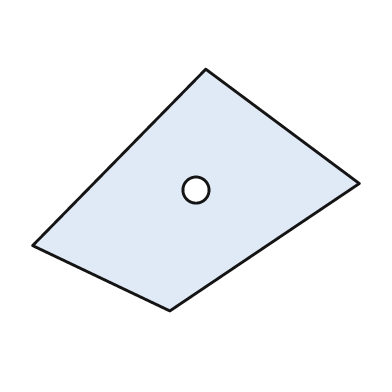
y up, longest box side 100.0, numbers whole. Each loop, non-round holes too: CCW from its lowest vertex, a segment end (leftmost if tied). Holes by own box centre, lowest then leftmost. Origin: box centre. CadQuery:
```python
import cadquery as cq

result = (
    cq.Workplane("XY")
    .moveTo(-8.0, -37.0)
    .lineTo(50.0, 2.0)
    .lineTo(3.0, 37.0)
    .lineTo(-50.0, -17.0)
    .close()
    .moveTo(0.0, 0.0)
    .circle(4.0)
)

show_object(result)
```